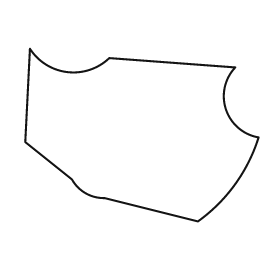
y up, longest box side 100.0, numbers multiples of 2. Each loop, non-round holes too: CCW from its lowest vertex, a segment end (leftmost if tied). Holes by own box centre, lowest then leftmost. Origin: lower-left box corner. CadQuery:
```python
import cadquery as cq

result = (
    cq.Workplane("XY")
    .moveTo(74.0, 0.0)
    .threePointArc((90.0, 16.0), (100.0, 36.0))
    .threePointArc((86.0, 48.0), (90.0, 66.0))
    .lineTo(36.0, 70.0)
    .threePointArc((18.0, 64.0), (2.0, 74.0))
    .lineTo(0.0, 34.0)
    .lineTo(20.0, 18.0)
    .threePointArc((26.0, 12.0), (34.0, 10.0))
    .close()
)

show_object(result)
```